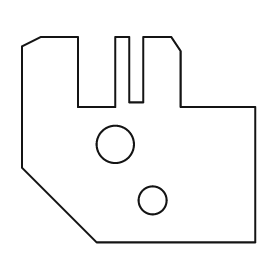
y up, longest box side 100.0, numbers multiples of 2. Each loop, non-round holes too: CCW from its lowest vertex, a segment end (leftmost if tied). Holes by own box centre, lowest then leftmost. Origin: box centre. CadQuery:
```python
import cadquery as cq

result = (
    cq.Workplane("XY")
    .moveTo(-18.0, -44.0)
    .lineTo(50.0, -44.0)
    .lineTo(50.0, 14.0)
    .lineTo(18.0, 14.0)
    .lineTo(18.0, 38.0)
    .lineTo(14.0, 44.0)
    .lineTo(2.0, 44.0)
    .lineTo(2.0, 16.0)
    .lineTo(-4.0, 16.0)
    .lineTo(-4.0, 44.0)
    .lineTo(-10.0, 44.0)
    .lineTo(-10.0, 14.0)
    .lineTo(-26.0, 14.0)
    .lineTo(-26.0, 44.0)
    .lineTo(-42.0, 44.0)
    .lineTo(-50.0, 40.0)
    .lineTo(-50.0, -12.0)
    .close()
    .moveTo(6.0, -26.0)
    .circle(6.0)
    .moveTo(-10.0, -2.0)
    .circle(8.0)
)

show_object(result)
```